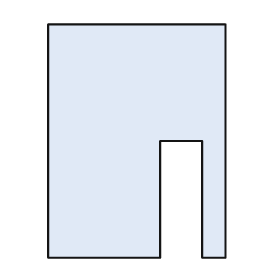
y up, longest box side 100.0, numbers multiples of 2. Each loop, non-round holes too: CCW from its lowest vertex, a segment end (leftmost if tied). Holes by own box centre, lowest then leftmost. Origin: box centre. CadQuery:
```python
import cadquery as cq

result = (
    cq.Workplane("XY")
    .moveTo(-38.0, -50.0)
    .lineTo(10.0, -50.0)
    .lineTo(10.0, 0.0)
    .lineTo(28.0, 0.0)
    .lineTo(28.0, -50.0)
    .lineTo(38.0, -50.0)
    .lineTo(38.0, 50.0)
    .lineTo(-38.0, 50.0)
    .close()
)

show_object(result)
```